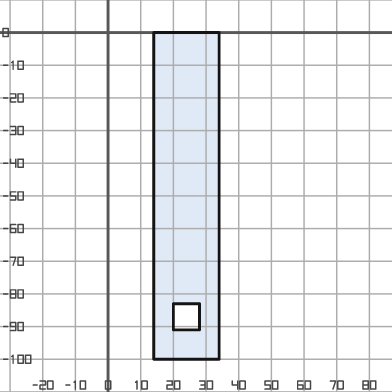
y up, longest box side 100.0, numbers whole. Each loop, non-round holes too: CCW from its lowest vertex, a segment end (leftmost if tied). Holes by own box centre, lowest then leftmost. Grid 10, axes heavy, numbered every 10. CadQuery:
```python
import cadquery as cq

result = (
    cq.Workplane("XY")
    .moveTo(14.0, -100.0)
    .lineTo(34.0, -100.0)
    .lineTo(34.0, 0.0)
    .lineTo(14.0, 0.0)
    .close()
    .moveTo(20.0, -91.0)
    .lineTo(28.0, -91.0)
    .lineTo(28.0, -83.0)
    .lineTo(20.0, -83.0)
    .close()
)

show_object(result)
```